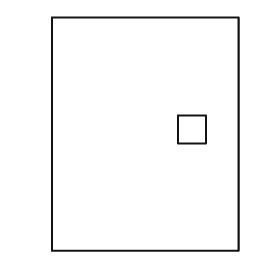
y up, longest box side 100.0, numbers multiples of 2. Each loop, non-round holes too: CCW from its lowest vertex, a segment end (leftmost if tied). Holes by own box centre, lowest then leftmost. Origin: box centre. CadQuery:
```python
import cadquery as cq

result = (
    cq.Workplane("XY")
    .moveTo(-40.0, -50.0)
    .lineTo(40.0, -50.0)
    .lineTo(40.0, 50.0)
    .lineTo(-40.0, 50.0)
    .close()
    .moveTo(14.0, -4.0)
    .lineTo(26.0, -4.0)
    .lineTo(26.0, 8.0)
    .lineTo(14.0, 8.0)
    .close()
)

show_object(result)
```